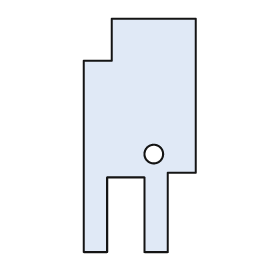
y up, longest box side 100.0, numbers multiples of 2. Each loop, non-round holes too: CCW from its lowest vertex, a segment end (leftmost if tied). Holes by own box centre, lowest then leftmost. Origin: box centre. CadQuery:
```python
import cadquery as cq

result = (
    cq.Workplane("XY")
    .moveTo(-24.0, -50.0)
    .lineTo(-14.0, -50.0)
    .lineTo(-14.0, -18.0)
    .lineTo(2.0, -18.0)
    .lineTo(2.0, -50.0)
    .lineTo(12.0, -50.0)
    .lineTo(12.0, -16.0)
    .lineTo(24.0, -16.0)
    .lineTo(24.0, 50.0)
    .lineTo(-12.0, 50.0)
    .lineTo(-12.0, 32.0)
    .lineTo(-24.0, 32.0)
    .close()
    .moveTo(6.0, -8.0)
    .circle(4.0)
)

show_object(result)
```